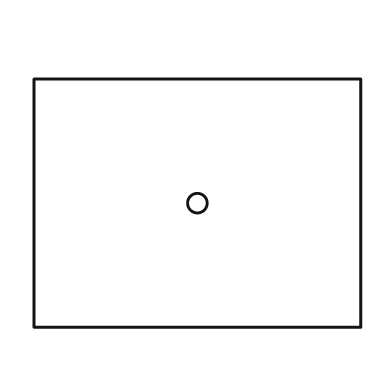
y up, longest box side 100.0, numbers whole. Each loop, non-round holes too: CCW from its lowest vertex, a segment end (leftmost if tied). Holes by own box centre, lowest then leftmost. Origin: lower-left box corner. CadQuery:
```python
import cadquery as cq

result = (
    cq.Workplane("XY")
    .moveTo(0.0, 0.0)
    .lineTo(100.0, 0.0)
    .lineTo(100.0, 76.0)
    .lineTo(0.0, 76.0)
    .close()
    .moveTo(50.0, 38.0)
    .circle(3.0)
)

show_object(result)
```